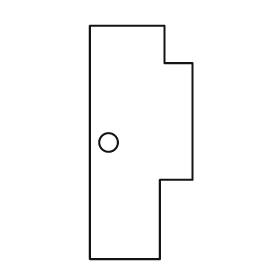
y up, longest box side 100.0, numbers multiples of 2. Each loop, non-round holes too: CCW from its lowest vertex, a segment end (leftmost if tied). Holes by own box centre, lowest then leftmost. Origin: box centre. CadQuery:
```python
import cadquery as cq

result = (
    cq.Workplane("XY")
    .moveTo(-22.0, -50.0)
    .lineTo(8.0, -50.0)
    .lineTo(8.0, -16.0)
    .lineTo(22.0, -16.0)
    .lineTo(22.0, 34.0)
    .lineTo(10.0, 34.0)
    .lineTo(10.0, 50.0)
    .lineTo(-22.0, 50.0)
    .close()
    .moveTo(-14.0, 0.0)
    .circle(4.0)
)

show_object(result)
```